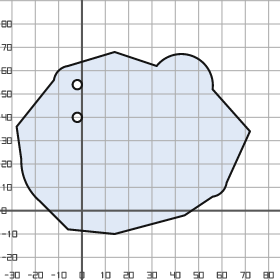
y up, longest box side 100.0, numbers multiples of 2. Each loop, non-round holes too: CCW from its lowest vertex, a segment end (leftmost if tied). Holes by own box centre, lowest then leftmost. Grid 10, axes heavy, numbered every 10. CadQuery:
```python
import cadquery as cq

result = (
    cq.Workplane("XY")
    .moveTo(14.0, -10.0)
    .lineTo(44.0, -2.0)
    .lineTo(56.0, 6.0)
    .threePointArc((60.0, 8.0), (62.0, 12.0))
    .lineTo(72.0, 34.0)
    .lineTo(56.0, 52.0)
    .threePointArc((48.0, 66.0), (32.0, 62.0))
    .lineTo(14.0, 68.0)
    .lineTo(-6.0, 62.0)
    .threePointArc((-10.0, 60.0), (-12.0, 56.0))
    .lineTo(-28.0, 36.0)
    .lineTo(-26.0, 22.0)
    .threePointArc((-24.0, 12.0), (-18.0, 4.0))
    .lineTo(-6.0, -8.0)
    .close()
    .moveTo(-2.0, 40.0)
    .circle(2.0)
    .moveTo(-2.0, 54.0)
    .circle(2.0)
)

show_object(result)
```